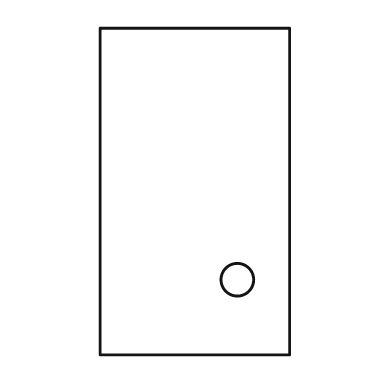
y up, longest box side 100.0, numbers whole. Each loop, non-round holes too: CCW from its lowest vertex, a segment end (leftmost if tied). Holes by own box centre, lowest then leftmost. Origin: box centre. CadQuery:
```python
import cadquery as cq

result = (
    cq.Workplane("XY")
    .moveTo(-29.0, -50.0)
    .lineTo(29.0, -50.0)
    .lineTo(29.0, 50.0)
    .lineTo(-29.0, 50.0)
    .close()
    .moveTo(13.0, -27.0)
    .circle(5.0)
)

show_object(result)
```